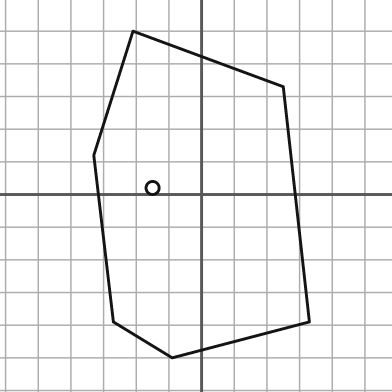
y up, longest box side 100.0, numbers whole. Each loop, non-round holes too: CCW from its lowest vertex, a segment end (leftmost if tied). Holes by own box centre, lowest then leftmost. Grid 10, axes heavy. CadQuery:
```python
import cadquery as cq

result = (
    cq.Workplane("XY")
    .moveTo(-9.0, -50.0)
    .lineTo(33.0, -39.0)
    .lineTo(25.0, 33.0)
    .lineTo(-21.0, 50.0)
    .lineTo(-33.0, 12.0)
    .lineTo(-27.0, -39.0)
    .close()
    .moveTo(-15.0, 2.0)
    .circle(2.0)
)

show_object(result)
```